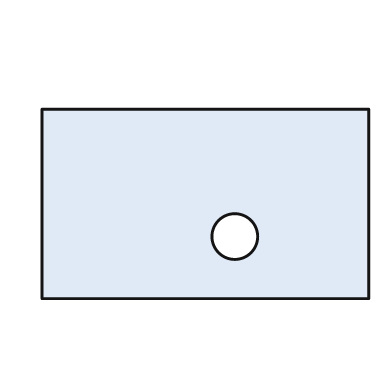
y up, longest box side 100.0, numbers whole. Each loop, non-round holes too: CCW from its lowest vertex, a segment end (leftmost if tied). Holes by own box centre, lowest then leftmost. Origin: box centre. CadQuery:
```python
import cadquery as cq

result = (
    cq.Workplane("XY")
    .moveTo(-50.0, -29.0)
    .lineTo(50.0, -29.0)
    .lineTo(50.0, 29.0)
    .lineTo(-50.0, 29.0)
    .close()
    .moveTo(9.0, -10.0)
    .circle(7.0)
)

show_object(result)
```